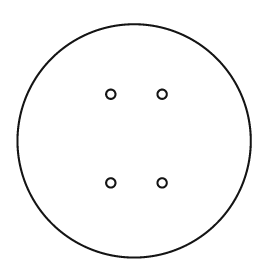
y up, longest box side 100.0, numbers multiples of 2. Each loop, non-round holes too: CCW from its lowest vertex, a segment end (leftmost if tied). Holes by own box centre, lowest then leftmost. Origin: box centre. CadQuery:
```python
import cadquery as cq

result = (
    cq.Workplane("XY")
    .moveTo(0.0, 0.0)
    .circle(50.0)
    .moveTo(-10.0, -18.0)
    .circle(2.0)
    .moveTo(12.0, -18.0)
    .circle(2.0)
    .moveTo(-10.0, 20.0)
    .circle(2.0)
    .moveTo(12.0, 20.0)
    .circle(2.0)
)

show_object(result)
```